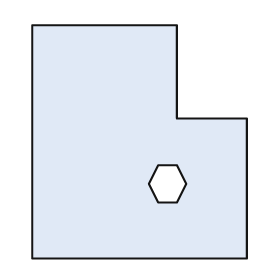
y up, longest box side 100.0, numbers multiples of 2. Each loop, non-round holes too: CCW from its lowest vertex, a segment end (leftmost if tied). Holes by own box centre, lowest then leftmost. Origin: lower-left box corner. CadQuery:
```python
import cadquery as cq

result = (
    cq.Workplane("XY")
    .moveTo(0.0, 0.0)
    .lineTo(92.0, 0.0)
    .lineTo(92.0, 60.0)
    .lineTo(62.0, 60.0)
    .lineTo(62.0, 100.0)
    .lineTo(0.0, 100.0)
    .close()
    .moveTo(54.0, 24.0)
    .lineTo(62.0, 24.0)
    .lineTo(66.0, 32.0)
    .lineTo(62.0, 40.0)
    .lineTo(54.0, 40.0)
    .lineTo(50.0, 32.0)
    .close()
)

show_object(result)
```